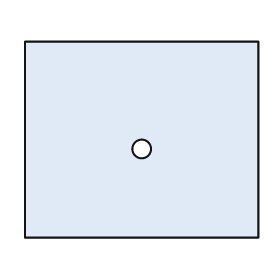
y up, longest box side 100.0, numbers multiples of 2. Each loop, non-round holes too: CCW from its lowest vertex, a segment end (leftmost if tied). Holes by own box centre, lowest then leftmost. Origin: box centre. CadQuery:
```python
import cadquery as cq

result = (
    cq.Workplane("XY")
    .moveTo(-50.0, -42.0)
    .lineTo(50.0, -42.0)
    .lineTo(50.0, 42.0)
    .lineTo(-50.0, 42.0)
    .close()
    .moveTo(0.0, -4.0)
    .circle(4.0)
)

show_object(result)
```